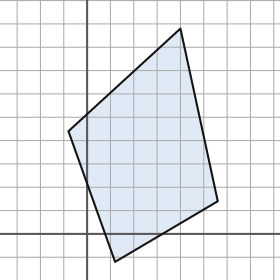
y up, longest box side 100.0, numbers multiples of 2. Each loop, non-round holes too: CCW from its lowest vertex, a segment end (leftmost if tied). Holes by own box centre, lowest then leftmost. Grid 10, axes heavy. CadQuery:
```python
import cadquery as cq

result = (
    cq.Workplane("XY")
    .moveTo(12.0, -12.0)
    .lineTo(56.0, 14.0)
    .lineTo(40.0, 88.0)
    .lineTo(-8.0, 44.0)
    .close()
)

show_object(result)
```